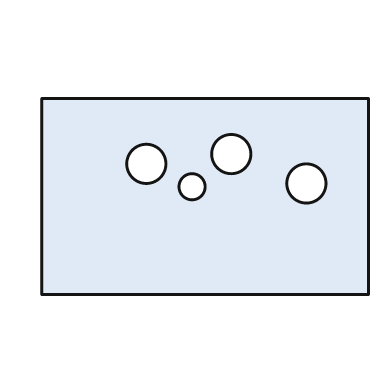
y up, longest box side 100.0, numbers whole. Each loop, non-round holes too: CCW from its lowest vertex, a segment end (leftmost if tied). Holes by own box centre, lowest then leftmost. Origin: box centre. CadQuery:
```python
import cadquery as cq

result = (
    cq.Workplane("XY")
    .moveTo(-50.0, -30.0)
    .lineTo(50.0, -30.0)
    .lineTo(50.0, 30.0)
    .lineTo(-50.0, 30.0)
    .close()
    .moveTo(-4.0, 3.0)
    .circle(4.0)
    .moveTo(31.0, 4.0)
    .circle(6.0)
    .moveTo(-18.0, 10.0)
    .circle(6.0)
    .moveTo(8.0, 13.0)
    .circle(6.0)
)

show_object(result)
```